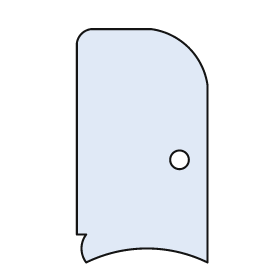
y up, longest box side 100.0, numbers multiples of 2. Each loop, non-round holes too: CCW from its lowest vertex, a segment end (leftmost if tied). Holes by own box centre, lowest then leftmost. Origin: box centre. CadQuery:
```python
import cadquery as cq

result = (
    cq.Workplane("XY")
    .moveTo(-24.0, -50.0)
    .threePointArc((2.0, -44.0), (28.0, -50.0))
    .lineTo(28.0, 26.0)
    .threePointArc((20.0, 42.0), (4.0, 50.0))
    .lineTo(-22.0, 50.0)
    .threePointArc((-26.0, 48.0), (-28.0, 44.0))
    .lineTo(-28.0, -38.0)
    .lineTo(-24.0, -38.0)
    .threePointArc((-26.0, -44.0), (-24.0, -50.0))
    .close()
    .moveTo(16.0, -6.0)
    .circle(4.0)
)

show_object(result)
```